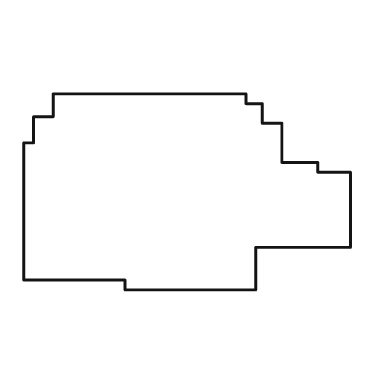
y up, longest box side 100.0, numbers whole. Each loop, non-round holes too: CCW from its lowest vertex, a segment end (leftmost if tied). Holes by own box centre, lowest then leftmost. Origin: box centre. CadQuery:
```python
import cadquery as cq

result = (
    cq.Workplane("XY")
    .moveTo(-19.0, -30.0)
    .lineTo(21.0, -30.0)
    .lineTo(21.0, -17.0)
    .lineTo(50.0, -17.0)
    .lineTo(50.0, 6.0)
    .lineTo(40.0, 6.0)
    .lineTo(40.0, 9.0)
    .lineTo(29.0, 9.0)
    .lineTo(29.0, 21.0)
    .lineTo(23.0, 21.0)
    .lineTo(23.0, 27.0)
    .lineTo(18.0, 27.0)
    .lineTo(18.0, 30.0)
    .lineTo(-41.0, 30.0)
    .lineTo(-41.0, 23.0)
    .lineTo(-47.0, 23.0)
    .lineTo(-47.0, 15.0)
    .lineTo(-50.0, 15.0)
    .lineTo(-50.0, -27.0)
    .lineTo(-19.0, -27.0)
    .close()
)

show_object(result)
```